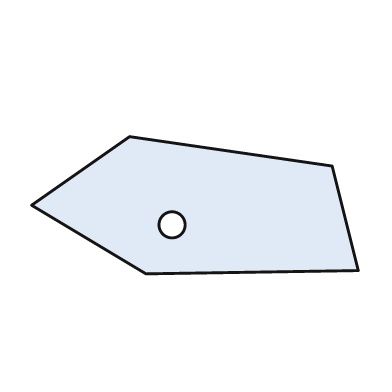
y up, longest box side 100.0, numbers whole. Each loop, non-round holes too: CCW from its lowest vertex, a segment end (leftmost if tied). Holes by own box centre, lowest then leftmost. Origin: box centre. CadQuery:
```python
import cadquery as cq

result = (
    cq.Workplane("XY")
    .moveTo(-15.0, -21.0)
    .lineTo(50.0, -20.0)
    .lineTo(42.0, 12.0)
    .lineTo(-20.0, 21.0)
    .lineTo(-50.0, 0.0)
    .close()
    .moveTo(-7.0, -6.0)
    .circle(4.0)
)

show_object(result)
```